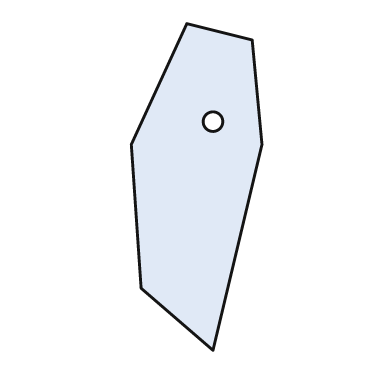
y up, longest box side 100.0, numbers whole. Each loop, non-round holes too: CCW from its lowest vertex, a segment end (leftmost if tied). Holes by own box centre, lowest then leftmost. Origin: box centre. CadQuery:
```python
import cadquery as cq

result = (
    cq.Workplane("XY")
    .moveTo(5.0, -50.0)
    .lineTo(20.0, 13.0)
    .lineTo(17.0, 45.0)
    .lineTo(-3.0, 50.0)
    .lineTo(-20.0, 13.0)
    .lineTo(-17.0, -31.0)
    .close()
    .moveTo(5.0, 20.0)
    .circle(3.0)
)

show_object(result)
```